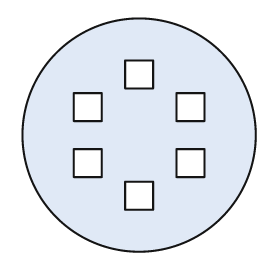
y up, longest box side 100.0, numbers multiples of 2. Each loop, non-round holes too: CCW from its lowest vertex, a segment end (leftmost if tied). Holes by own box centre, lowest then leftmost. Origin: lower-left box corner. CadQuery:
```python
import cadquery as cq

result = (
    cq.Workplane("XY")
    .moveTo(50.0, 50.0)
    .circle(50.0)
    .moveTo(44.0, 18.0)
    .lineTo(56.0, 18.0)
    .lineTo(56.0, 30.0)
    .lineTo(44.0, 30.0)
    .close()
    .moveTo(22.0, 32.0)
    .lineTo(34.0, 32.0)
    .lineTo(34.0, 44.0)
    .lineTo(22.0, 44.0)
    .close()
    .moveTo(66.0, 32.0)
    .lineTo(78.0, 32.0)
    .lineTo(78.0, 44.0)
    .lineTo(66.0, 44.0)
    .close()
    .moveTo(22.0, 56.0)
    .lineTo(34.0, 56.0)
    .lineTo(34.0, 68.0)
    .lineTo(22.0, 68.0)
    .close()
    .moveTo(66.0, 56.0)
    .lineTo(78.0, 56.0)
    .lineTo(78.0, 68.0)
    .lineTo(66.0, 68.0)
    .close()
    .moveTo(44.0, 70.0)
    .lineTo(56.0, 70.0)
    .lineTo(56.0, 82.0)
    .lineTo(44.0, 82.0)
    .close()
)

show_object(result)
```